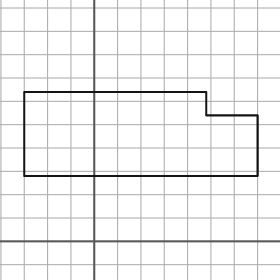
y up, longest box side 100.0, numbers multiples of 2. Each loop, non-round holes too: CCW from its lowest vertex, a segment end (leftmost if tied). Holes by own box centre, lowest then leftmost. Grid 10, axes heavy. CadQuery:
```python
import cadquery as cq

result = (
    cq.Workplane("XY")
    .moveTo(-30.0, 28.0)
    .lineTo(70.0, 28.0)
    .lineTo(70.0, 54.0)
    .lineTo(48.0, 54.0)
    .lineTo(48.0, 64.0)
    .lineTo(-30.0, 64.0)
    .close()
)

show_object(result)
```